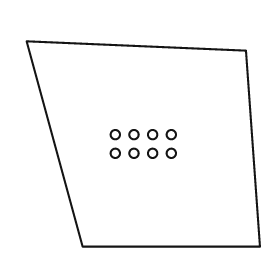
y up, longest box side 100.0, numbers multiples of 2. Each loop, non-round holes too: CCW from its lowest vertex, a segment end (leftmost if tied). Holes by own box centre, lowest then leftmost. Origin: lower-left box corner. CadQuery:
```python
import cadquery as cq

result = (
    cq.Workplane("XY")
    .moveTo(24.0, 0.0)
    .lineTo(100.0, 0.0)
    .lineTo(94.0, 84.0)
    .lineTo(0.0, 88.0)
    .close()
    .moveTo(38.0, 40.0)
    .circle(2.0)
    .moveTo(46.0, 40.0)
    .circle(2.0)
    .moveTo(54.0, 40.0)
    .circle(2.0)
    .moveTo(62.0, 40.0)
    .circle(2.0)
    .moveTo(38.0, 48.0)
    .circle(2.0)
    .moveTo(46.0, 48.0)
    .circle(2.0)
    .moveTo(54.0, 48.0)
    .circle(2.0)
    .moveTo(62.0, 48.0)
    .circle(2.0)
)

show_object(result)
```